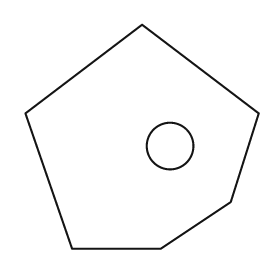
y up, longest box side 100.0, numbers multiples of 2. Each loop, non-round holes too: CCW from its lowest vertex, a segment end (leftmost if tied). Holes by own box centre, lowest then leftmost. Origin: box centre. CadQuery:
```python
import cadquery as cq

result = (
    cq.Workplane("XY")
    .moveTo(-30.0, -48.0)
    .lineTo(8.0, -48.0)
    .lineTo(38.0, -28.0)
    .lineTo(50.0, 10.0)
    .lineTo(0.0, 48.0)
    .lineTo(-50.0, 10.0)
    .close()
    .moveTo(12.0, -4.0)
    .circle(10.0)
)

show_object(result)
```